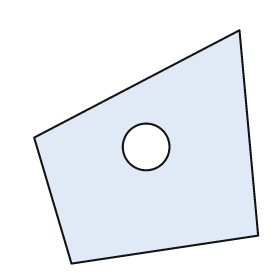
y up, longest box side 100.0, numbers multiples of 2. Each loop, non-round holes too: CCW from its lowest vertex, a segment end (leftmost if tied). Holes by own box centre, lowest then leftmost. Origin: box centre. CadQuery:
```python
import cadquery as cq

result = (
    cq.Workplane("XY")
    .moveTo(-32.0, -50.0)
    .lineTo(48.0, -38.0)
    .lineTo(40.0, 50.0)
    .lineTo(-48.0, 4.0)
    .close()
    .moveTo(0.0, 0.0)
    .circle(10.0)
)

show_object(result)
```